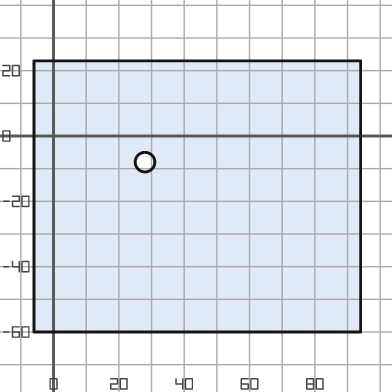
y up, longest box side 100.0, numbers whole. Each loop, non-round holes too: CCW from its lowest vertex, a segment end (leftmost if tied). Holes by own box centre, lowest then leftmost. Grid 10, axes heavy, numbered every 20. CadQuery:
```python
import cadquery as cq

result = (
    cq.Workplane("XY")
    .moveTo(-6.0, -60.0)
    .lineTo(94.0, -60.0)
    .lineTo(94.0, 23.0)
    .lineTo(-6.0, 23.0)
    .close()
    .moveTo(28.0, -8.0)
    .circle(3.0)
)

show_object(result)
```